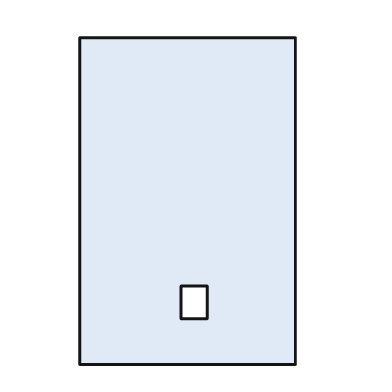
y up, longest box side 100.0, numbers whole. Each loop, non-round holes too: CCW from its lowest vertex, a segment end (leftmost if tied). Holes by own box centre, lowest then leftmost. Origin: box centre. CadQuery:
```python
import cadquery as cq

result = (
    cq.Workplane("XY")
    .moveTo(-33.0, -50.0)
    .lineTo(33.0, -50.0)
    .lineTo(33.0, 50.0)
    .lineTo(-33.0, 50.0)
    .close()
    .moveTo(-2.0, -36.0)
    .lineTo(6.0, -36.0)
    .lineTo(6.0, -26.0)
    .lineTo(-2.0, -26.0)
    .close()
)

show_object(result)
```